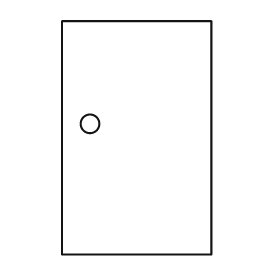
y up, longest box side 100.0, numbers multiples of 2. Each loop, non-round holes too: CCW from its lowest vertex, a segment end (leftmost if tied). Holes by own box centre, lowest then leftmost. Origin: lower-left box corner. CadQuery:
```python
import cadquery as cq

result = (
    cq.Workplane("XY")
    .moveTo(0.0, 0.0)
    .lineTo(64.0, 0.0)
    .lineTo(64.0, 100.0)
    .lineTo(0.0, 100.0)
    .close()
    .moveTo(12.0, 56.0)
    .circle(4.0)
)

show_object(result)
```